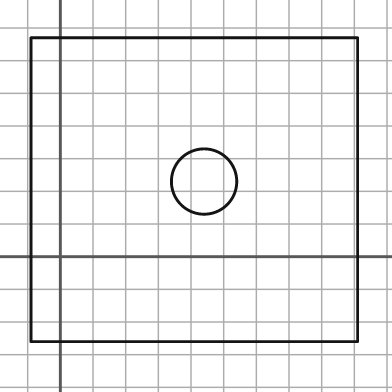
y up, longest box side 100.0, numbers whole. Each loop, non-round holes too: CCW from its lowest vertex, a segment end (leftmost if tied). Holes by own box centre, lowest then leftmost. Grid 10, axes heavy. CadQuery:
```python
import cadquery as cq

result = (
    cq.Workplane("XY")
    .moveTo(-9.0, -26.0)
    .lineTo(91.0, -26.0)
    .lineTo(91.0, 67.0)
    .lineTo(-9.0, 67.0)
    .close()
    .moveTo(44.0, 23.0)
    .circle(10.0)
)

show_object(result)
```